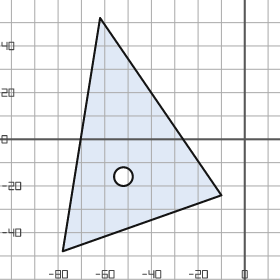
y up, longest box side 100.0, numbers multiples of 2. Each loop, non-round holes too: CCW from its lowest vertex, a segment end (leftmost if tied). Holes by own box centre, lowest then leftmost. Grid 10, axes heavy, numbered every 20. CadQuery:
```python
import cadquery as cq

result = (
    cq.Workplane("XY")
    .moveTo(-78.0, -48.0)
    .lineTo(-10.0, -24.0)
    .lineTo(-62.0, 52.0)
    .close()
    .moveTo(-52.0, -16.0)
    .circle(4.0)
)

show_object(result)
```